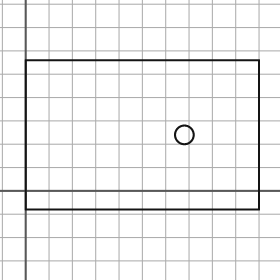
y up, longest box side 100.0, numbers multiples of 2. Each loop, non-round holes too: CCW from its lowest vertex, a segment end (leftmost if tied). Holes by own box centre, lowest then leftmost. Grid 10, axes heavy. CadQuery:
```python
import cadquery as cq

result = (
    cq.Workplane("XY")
    .moveTo(0.0, -8.0)
    .lineTo(100.0, -8.0)
    .lineTo(100.0, 56.0)
    .lineTo(0.0, 56.0)
    .close()
    .moveTo(68.0, 24.0)
    .circle(4.0)
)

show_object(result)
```